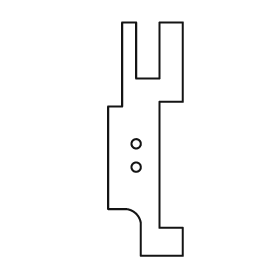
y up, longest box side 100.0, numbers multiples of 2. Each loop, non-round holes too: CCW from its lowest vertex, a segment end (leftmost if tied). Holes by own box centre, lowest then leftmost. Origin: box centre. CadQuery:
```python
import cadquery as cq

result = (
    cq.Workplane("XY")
    .moveTo(-2.0, -50.0)
    .lineTo(16.0, -50.0)
    .lineTo(16.0, -38.0)
    .lineTo(6.0, -38.0)
    .lineTo(6.0, 16.0)
    .lineTo(16.0, 16.0)
    .lineTo(16.0, 50.0)
    .lineTo(6.0, 50.0)
    .lineTo(6.0, 26.0)
    .lineTo(-4.0, 26.0)
    .lineTo(-4.0, 50.0)
    .lineTo(-10.0, 50.0)
    .lineTo(-10.0, 14.0)
    .lineTo(-16.0, 14.0)
    .lineTo(-16.0, -30.0)
    .lineTo(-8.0, -30.0)
    .threePointArc((-4.0, -32.0), (-2.0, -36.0))
    .close()
    .moveTo(-4.0, -12.0)
    .circle(2.0)
    .moveTo(-4.0, -2.0)
    .circle(2.0)
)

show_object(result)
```